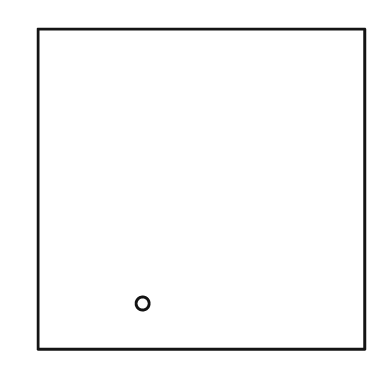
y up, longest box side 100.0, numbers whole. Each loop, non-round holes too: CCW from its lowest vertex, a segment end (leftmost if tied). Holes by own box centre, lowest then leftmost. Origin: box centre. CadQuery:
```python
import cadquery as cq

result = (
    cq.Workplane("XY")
    .moveTo(-50.0, -49.0)
    .lineTo(50.0, -49.0)
    .lineTo(50.0, 49.0)
    .lineTo(-50.0, 49.0)
    .close()
    .moveTo(-18.0, -35.0)
    .circle(2.0)
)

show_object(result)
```